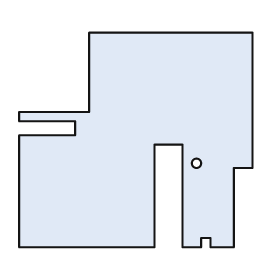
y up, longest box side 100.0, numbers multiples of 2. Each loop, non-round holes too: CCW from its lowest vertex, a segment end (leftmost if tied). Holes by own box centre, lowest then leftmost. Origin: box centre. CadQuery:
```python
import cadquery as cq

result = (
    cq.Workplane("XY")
    .moveTo(-50.0, -46.0)
    .lineTo(8.0, -46.0)
    .lineTo(8.0, -2.0)
    .lineTo(20.0, -2.0)
    .lineTo(20.0, -46.0)
    .lineTo(28.0, -46.0)
    .lineTo(28.0, -42.0)
    .lineTo(32.0, -42.0)
    .lineTo(32.0, -46.0)
    .lineTo(42.0, -46.0)
    .lineTo(42.0, -12.0)
    .lineTo(50.0, -12.0)
    .lineTo(50.0, 46.0)
    .lineTo(-20.0, 46.0)
    .lineTo(-20.0, 12.0)
    .lineTo(-50.0, 12.0)
    .lineTo(-50.0, 8.0)
    .lineTo(-26.0, 8.0)
    .lineTo(-26.0, 2.0)
    .lineTo(-50.0, 2.0)
    .close()
    .moveTo(26.0, -10.0)
    .circle(2.0)
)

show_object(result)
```